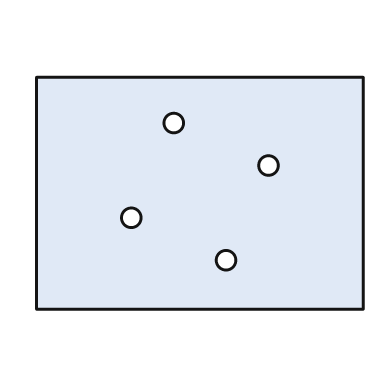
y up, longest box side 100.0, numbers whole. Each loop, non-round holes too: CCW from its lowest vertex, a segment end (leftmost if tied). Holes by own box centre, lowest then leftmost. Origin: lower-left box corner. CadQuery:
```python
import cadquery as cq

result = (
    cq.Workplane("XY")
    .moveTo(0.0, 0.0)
    .lineTo(100.0, 0.0)
    .lineTo(100.0, 71.0)
    .lineTo(0.0, 71.0)
    .close()
    .moveTo(58.0, 15.0)
    .circle(3.0)
    .moveTo(29.0, 28.0)
    .circle(3.0)
    .moveTo(71.0, 44.0)
    .circle(3.0)
    .moveTo(42.0, 57.0)
    .circle(3.0)
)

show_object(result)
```